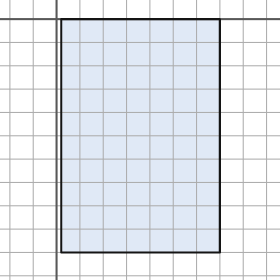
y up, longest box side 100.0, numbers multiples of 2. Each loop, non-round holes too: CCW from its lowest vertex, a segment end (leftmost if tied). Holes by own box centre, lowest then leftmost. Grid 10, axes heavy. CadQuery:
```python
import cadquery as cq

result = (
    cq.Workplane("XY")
    .moveTo(2.0, -100.0)
    .lineTo(70.0, -100.0)
    .lineTo(70.0, 0.0)
    .lineTo(2.0, 0.0)
    .close()
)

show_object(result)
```